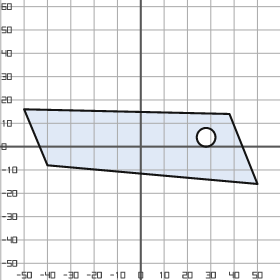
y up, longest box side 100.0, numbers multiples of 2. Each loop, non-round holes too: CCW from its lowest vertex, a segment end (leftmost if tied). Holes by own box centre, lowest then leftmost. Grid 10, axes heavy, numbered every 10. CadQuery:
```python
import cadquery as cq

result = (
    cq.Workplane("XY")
    .moveTo(50.0, -16.0)
    .lineTo(38.0, 14.0)
    .lineTo(-50.0, 16.0)
    .lineTo(-40.0, -8.0)
    .close()
    .moveTo(28.0, 4.0)
    .circle(4.0)
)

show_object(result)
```